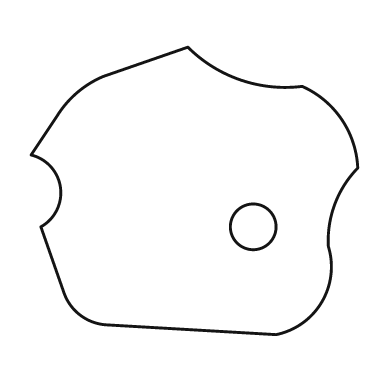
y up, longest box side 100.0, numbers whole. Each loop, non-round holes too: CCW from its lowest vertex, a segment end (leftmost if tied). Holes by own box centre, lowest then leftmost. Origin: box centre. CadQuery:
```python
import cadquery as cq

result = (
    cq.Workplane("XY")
    .moveTo(25.0, -44.0)
    .threePointArc((39.0, -34.0), (41.0, -17.0))
    .threePointArc((43.0, -4.0), (50.0, 7.0))
    .threePointArc((45.0, 22.0), (33.0, 32.0))
    .threePointArc((14.0, 34.0), (-2.0, 44.0))
    .lineTo(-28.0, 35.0)
    .threePointArc((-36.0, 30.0), (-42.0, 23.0))
    .lineTo(-50.0, 11.0)
    .threePointArc((-41.0, 1.0), (-47.0, -11.0))
    .lineTo(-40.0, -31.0)
    .threePointArc((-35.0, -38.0), (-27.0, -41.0))
    .close()
    .moveTo(18.0, -11.0)
    .circle(7.0)
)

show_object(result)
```